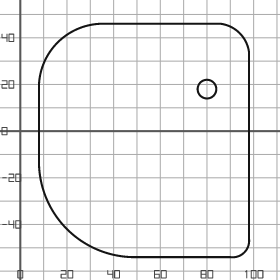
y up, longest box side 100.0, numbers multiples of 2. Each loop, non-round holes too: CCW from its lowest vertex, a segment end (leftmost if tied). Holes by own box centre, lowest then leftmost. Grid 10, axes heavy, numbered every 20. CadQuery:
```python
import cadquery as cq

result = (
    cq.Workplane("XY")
    .moveTo(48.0, -54.0)
    .lineTo(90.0, -54.0)
    .threePointArc((96.0, -52.0), (98.0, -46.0))
    .lineTo(98.0, 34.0)
    .threePointArc((94.0, 42.0), (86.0, 46.0))
    .lineTo(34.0, 46.0)
    .threePointArc((16.0, 38.0), (8.0, 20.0))
    .lineTo(8.0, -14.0)
    .threePointArc((20.0, -42.0), (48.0, -54.0))
    .close()
    .moveTo(80.0, 18.0)
    .circle(4.0)
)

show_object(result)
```